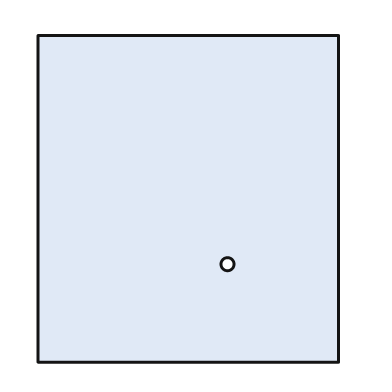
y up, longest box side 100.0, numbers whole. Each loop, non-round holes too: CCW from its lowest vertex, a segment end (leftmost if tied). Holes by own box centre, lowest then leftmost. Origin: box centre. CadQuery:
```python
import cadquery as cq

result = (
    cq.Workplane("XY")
    .moveTo(-46.0, -50.0)
    .lineTo(46.0, -50.0)
    .lineTo(46.0, 50.0)
    .lineTo(-46.0, 50.0)
    .close()
    .moveTo(12.0, -20.0)
    .circle(2.0)
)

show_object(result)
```